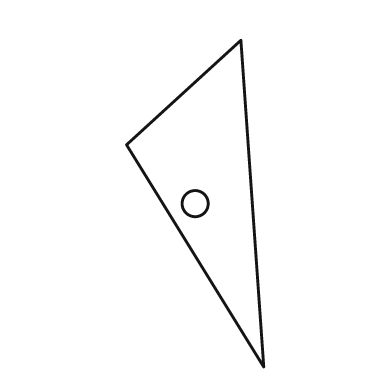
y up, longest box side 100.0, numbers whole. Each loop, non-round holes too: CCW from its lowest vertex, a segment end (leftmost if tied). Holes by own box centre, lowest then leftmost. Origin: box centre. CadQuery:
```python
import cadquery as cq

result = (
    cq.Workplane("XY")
    .moveTo(21.0, -50.0)
    .lineTo(14.0, 50.0)
    .lineTo(-21.0, 18.0)
    .close()
    .moveTo(0.0, 0.0)
    .circle(4.0)
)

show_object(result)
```